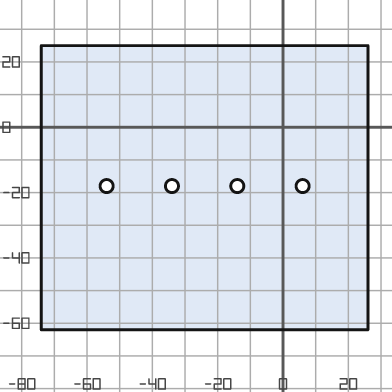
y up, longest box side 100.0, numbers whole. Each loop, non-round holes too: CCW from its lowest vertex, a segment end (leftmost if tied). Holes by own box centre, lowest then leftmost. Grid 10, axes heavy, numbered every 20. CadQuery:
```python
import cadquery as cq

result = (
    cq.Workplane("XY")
    .moveTo(-74.0, -62.0)
    .lineTo(26.0, -62.0)
    .lineTo(26.0, 25.0)
    .lineTo(-74.0, 25.0)
    .close()
    .moveTo(-54.0, -18.0)
    .circle(2.0)
    .moveTo(-34.0, -18.0)
    .circle(2.0)
    .moveTo(-14.0, -18.0)
    .circle(2.0)
    .moveTo(6.0, -18.0)
    .circle(2.0)
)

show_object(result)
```